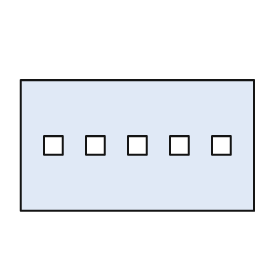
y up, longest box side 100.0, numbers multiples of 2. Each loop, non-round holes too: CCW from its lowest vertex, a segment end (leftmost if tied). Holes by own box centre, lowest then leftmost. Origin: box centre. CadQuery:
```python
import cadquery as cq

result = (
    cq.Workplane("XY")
    .moveTo(-50.0, -28.0)
    .lineTo(50.0, -28.0)
    .lineTo(50.0, 28.0)
    .lineTo(-50.0, 28.0)
    .close()
    .moveTo(-40.0, -4.0)
    .lineTo(-32.0, -4.0)
    .lineTo(-32.0, 4.0)
    .lineTo(-40.0, 4.0)
    .close()
    .moveTo(-22.0, -4.0)
    .lineTo(-14.0, -4.0)
    .lineTo(-14.0, 4.0)
    .lineTo(-22.0, 4.0)
    .close()
    .moveTo(-4.0, -4.0)
    .lineTo(4.0, -4.0)
    .lineTo(4.0, 4.0)
    .lineTo(-4.0, 4.0)
    .close()
    .moveTo(14.0, -4.0)
    .lineTo(22.0, -4.0)
    .lineTo(22.0, 4.0)
    .lineTo(14.0, 4.0)
    .close()
    .moveTo(32.0, -4.0)
    .lineTo(40.0, -4.0)
    .lineTo(40.0, 4.0)
    .lineTo(32.0, 4.0)
    .close()
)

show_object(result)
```